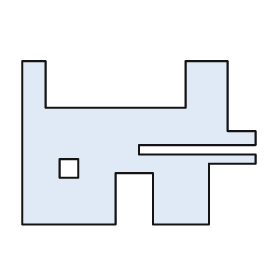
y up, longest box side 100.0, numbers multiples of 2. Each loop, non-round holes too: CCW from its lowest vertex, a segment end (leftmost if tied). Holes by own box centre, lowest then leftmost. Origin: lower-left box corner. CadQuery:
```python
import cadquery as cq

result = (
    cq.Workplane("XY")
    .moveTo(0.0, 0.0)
    .lineTo(40.0, 0.0)
    .lineTo(40.0, 22.0)
    .lineTo(56.0, 22.0)
    .lineTo(56.0, 0.0)
    .lineTo(80.0, 0.0)
    .lineTo(80.0, 26.0)
    .lineTo(100.0, 26.0)
    .lineTo(100.0, 30.0)
    .lineTo(50.0, 30.0)
    .lineTo(50.0, 34.0)
    .lineTo(100.0, 34.0)
    .lineTo(100.0, 40.0)
    .lineTo(88.0, 40.0)
    .lineTo(88.0, 70.0)
    .lineTo(70.0, 70.0)
    .lineTo(70.0, 50.0)
    .lineTo(10.0, 50.0)
    .lineTo(10.0, 70.0)
    .lineTo(0.0, 70.0)
    .close()
    .moveTo(16.0, 20.0)
    .lineTo(24.0, 20.0)
    .lineTo(24.0, 28.0)
    .lineTo(16.0, 28.0)
    .close()
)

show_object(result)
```